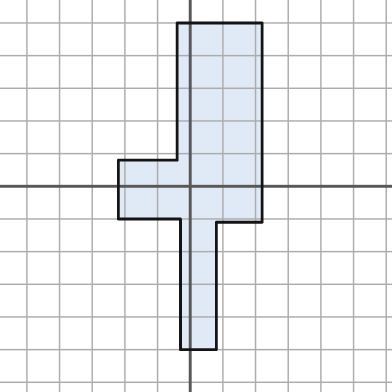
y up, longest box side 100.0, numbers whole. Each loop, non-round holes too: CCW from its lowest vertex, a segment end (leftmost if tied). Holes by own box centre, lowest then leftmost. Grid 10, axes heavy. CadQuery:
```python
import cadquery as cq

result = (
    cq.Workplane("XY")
    .moveTo(-3.0, -50.0)
    .lineTo(8.0, -50.0)
    .lineTo(8.0, -11.0)
    .lineTo(22.0, -11.0)
    .lineTo(22.0, 50.0)
    .lineTo(-4.0, 50.0)
    .lineTo(-4.0, 8.0)
    .lineTo(-22.0, 8.0)
    .lineTo(-22.0, -10.0)
    .lineTo(-3.0, -10.0)
    .close()
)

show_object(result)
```